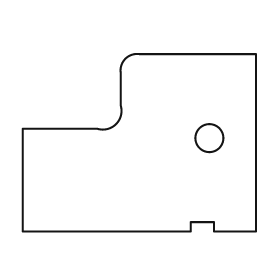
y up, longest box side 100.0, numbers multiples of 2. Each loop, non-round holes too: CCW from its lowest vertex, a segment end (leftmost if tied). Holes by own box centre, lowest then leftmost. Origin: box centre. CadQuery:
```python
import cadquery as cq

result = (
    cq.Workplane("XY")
    .moveTo(-50.0, -38.0)
    .lineTo(22.0, -38.0)
    .lineTo(22.0, -34.0)
    .lineTo(32.0, -34.0)
    .lineTo(32.0, -38.0)
    .lineTo(50.0, -38.0)
    .lineTo(50.0, 38.0)
    .lineTo(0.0, 38.0)
    .threePointArc((-6.0, 36.0), (-8.0, 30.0))
    .lineTo(-8.0, 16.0)
    .threePointArc((-10.0, 8.0), (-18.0, 6.0))
    .lineTo(-50.0, 6.0)
    .close()
    .moveTo(30.0, 2.0)
    .circle(6.0)
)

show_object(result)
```